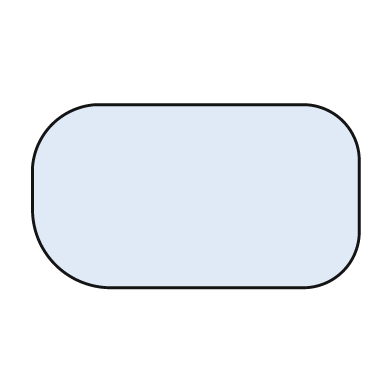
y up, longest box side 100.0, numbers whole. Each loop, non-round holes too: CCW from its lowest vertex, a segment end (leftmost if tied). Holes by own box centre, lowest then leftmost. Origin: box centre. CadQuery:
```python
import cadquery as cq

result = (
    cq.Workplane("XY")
    .moveTo(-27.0, -28.0)
    .lineTo(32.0, -28.0)
    .threePointArc((45.0, -23.0), (50.0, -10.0))
    .lineTo(50.0, 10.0)
    .threePointArc((45.0, 23.0), (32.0, 28.0))
    .lineTo(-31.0, 28.0)
    .threePointArc((-44.0, 22.0), (-50.0, 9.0))
    .lineTo(-50.0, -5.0)
    .threePointArc((-43.0, -21.0), (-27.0, -28.0))
    .close()
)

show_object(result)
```